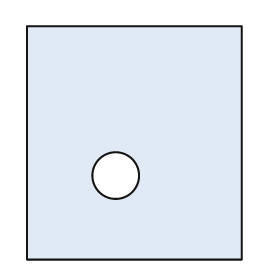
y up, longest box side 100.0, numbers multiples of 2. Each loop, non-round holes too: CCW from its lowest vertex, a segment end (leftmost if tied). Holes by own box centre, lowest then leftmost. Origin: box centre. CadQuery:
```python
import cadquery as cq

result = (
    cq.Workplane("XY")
    .moveTo(-46.0, -50.0)
    .lineTo(46.0, -50.0)
    .lineTo(46.0, 50.0)
    .lineTo(-46.0, 50.0)
    .close()
    .moveTo(-8.0, -14.0)
    .circle(10.0)
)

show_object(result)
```